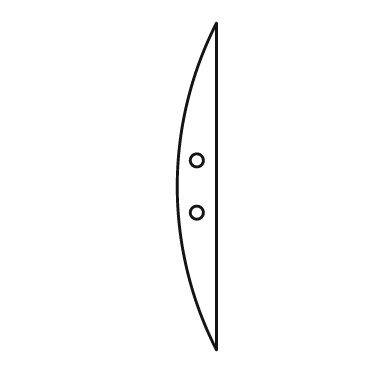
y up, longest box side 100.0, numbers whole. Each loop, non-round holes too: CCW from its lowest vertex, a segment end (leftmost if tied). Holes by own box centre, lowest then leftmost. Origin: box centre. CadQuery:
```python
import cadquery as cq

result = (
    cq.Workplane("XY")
    .moveTo(6.0, -50.0)
    .lineTo(6.0, 50.0)
    .threePointArc((-6.0, 0.0), (6.0, -50.0))
    .close()
    .moveTo(0.0, -8.0)
    .circle(2.0)
    .moveTo(0.0, 8.0)
    .circle(2.0)
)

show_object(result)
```